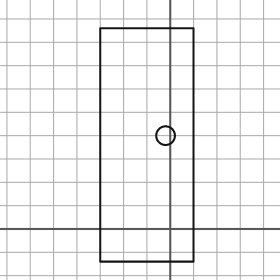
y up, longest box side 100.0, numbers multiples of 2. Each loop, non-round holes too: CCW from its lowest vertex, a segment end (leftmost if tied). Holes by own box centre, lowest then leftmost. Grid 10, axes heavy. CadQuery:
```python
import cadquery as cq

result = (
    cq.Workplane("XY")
    .moveTo(-30.0, -14.0)
    .lineTo(10.0, -14.0)
    .lineTo(10.0, 86.0)
    .lineTo(-30.0, 86.0)
    .close()
    .moveTo(-2.0, 40.0)
    .circle(4.0)
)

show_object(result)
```